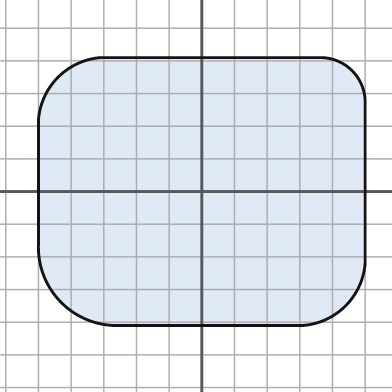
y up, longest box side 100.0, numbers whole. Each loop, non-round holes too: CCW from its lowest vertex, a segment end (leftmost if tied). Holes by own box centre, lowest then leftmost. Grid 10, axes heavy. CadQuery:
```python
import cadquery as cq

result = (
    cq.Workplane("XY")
    .moveTo(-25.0, -41.0)
    .lineTo(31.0, -41.0)
    .threePointArc((44.0, -35.0), (50.0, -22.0))
    .lineTo(50.0, 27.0)
    .threePointArc((46.0, 37.0), (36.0, 41.0))
    .lineTo(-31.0, 41.0)
    .threePointArc((-44.0, 35.0), (-50.0, 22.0))
    .lineTo(-50.0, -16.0)
    .threePointArc((-43.0, -34.0), (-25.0, -41.0))
    .close()
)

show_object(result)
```